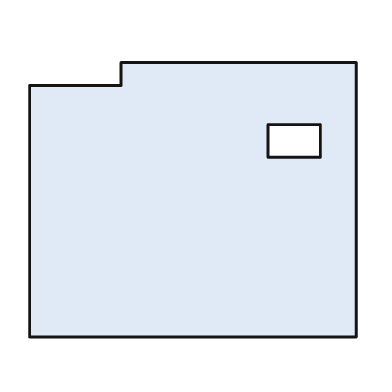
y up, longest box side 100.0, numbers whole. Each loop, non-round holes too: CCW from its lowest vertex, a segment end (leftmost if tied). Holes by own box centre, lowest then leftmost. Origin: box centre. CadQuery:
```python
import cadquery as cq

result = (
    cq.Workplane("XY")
    .moveTo(-50.0, -42.0)
    .lineTo(50.0, -42.0)
    .lineTo(50.0, 42.0)
    .lineTo(-22.0, 42.0)
    .lineTo(-22.0, 35.0)
    .lineTo(-50.0, 35.0)
    .close()
    .moveTo(23.0, 13.0)
    .lineTo(39.0, 13.0)
    .lineTo(39.0, 23.0)
    .lineTo(23.0, 23.0)
    .close()
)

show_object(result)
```